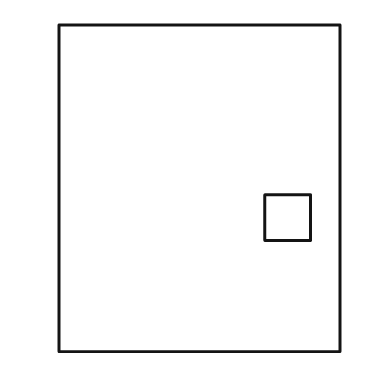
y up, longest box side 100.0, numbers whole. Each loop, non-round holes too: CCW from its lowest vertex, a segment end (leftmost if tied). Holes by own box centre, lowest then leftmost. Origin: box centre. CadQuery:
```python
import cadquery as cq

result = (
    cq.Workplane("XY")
    .moveTo(-43.0, -50.0)
    .lineTo(43.0, -50.0)
    .lineTo(43.0, 50.0)
    .lineTo(-43.0, 50.0)
    .close()
    .moveTo(20.0, -16.0)
    .lineTo(34.0, -16.0)
    .lineTo(34.0, -2.0)
    .lineTo(20.0, -2.0)
    .close()
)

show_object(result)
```